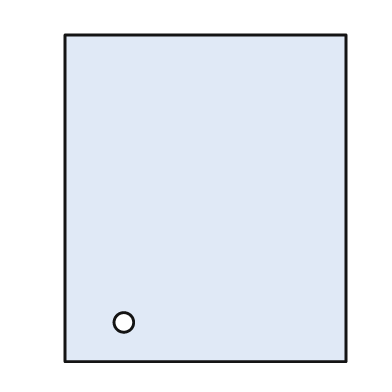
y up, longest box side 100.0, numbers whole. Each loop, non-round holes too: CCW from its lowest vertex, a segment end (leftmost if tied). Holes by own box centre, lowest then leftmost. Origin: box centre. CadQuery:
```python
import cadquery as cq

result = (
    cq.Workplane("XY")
    .moveTo(-43.0, -50.0)
    .lineTo(43.0, -50.0)
    .lineTo(43.0, 50.0)
    .lineTo(-43.0, 50.0)
    .close()
    .moveTo(-25.0, -38.0)
    .circle(3.0)
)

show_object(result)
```